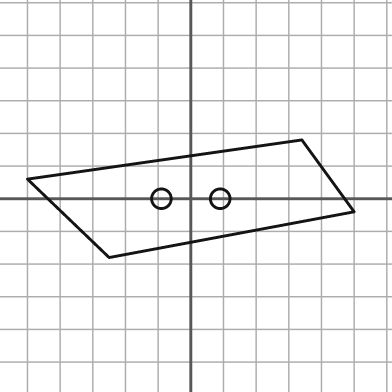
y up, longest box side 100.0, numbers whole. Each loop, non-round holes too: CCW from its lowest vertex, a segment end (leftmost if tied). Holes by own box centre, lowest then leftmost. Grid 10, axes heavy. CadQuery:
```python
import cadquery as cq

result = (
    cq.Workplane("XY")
    .moveTo(-25.0, -18.0)
    .lineTo(50.0, -4.0)
    .lineTo(34.0, 18.0)
    .lineTo(-50.0, 6.0)
    .close()
    .moveTo(-9.0, 0.0)
    .circle(3.0)
    .moveTo(9.0, 0.0)
    .circle(3.0)
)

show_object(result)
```